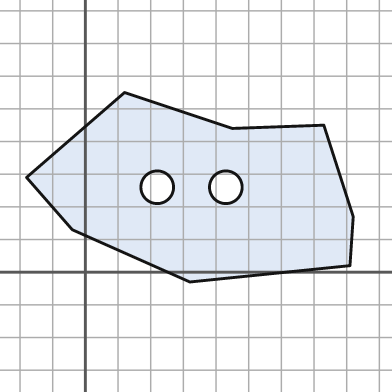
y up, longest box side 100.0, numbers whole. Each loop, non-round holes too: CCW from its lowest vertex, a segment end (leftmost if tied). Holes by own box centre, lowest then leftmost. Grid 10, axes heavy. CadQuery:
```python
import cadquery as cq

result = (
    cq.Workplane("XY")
    .moveTo(32.0, -3.0)
    .lineTo(81.0, 2.0)
    .lineTo(82.0, 17.0)
    .lineTo(73.0, 45.0)
    .lineTo(45.0, 44.0)
    .lineTo(12.0, 55.0)
    .lineTo(-18.0, 29.0)
    .lineTo(-4.0, 13.0)
    .close()
    .moveTo(22.0, 26.0)
    .circle(5.0)
    .moveTo(43.0, 26.0)
    .circle(5.0)
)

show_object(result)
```